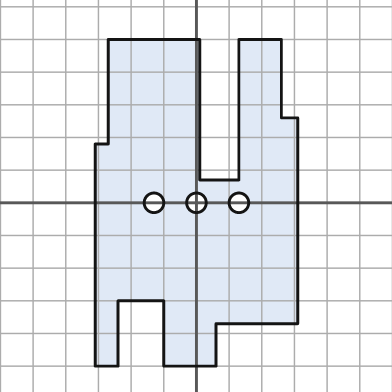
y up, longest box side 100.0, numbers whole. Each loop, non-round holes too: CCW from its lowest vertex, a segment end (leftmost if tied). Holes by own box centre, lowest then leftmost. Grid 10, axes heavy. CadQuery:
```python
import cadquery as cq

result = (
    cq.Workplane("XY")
    .moveTo(-31.0, -50.0)
    .lineTo(-24.0, -50.0)
    .lineTo(-24.0, -30.0)
    .lineTo(-10.0, -30.0)
    .lineTo(-10.0, -50.0)
    .lineTo(6.0, -50.0)
    .lineTo(6.0, -37.0)
    .lineTo(31.0, -37.0)
    .lineTo(31.0, 26.0)
    .lineTo(26.0, 26.0)
    .lineTo(26.0, 50.0)
    .lineTo(13.0, 50.0)
    .lineTo(13.0, 7.0)
    .lineTo(1.0, 7.0)
    .lineTo(1.0, 50.0)
    .lineTo(-27.0, 50.0)
    .lineTo(-27.0, 18.0)
    .lineTo(-31.0, 18.0)
    .close()
    .moveTo(-13.0, 0.0)
    .circle(3.0)
    .moveTo(0.0, 0.0)
    .circle(3.0)
    .moveTo(13.0, 0.0)
    .circle(3.0)
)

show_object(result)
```